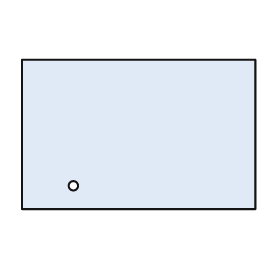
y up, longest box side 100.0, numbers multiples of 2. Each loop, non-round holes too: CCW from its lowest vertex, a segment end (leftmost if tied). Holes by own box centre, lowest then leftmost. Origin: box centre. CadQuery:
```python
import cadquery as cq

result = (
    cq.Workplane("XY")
    .moveTo(-50.0, -32.0)
    .lineTo(50.0, -32.0)
    .lineTo(50.0, 32.0)
    .lineTo(-50.0, 32.0)
    .close()
    .moveTo(-28.0, -22.0)
    .circle(2.0)
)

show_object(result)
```